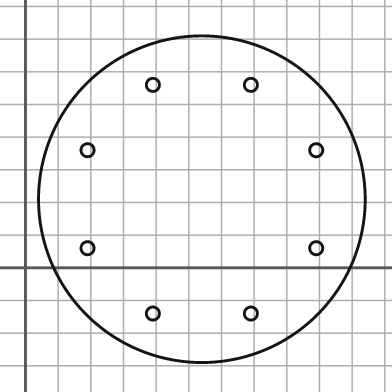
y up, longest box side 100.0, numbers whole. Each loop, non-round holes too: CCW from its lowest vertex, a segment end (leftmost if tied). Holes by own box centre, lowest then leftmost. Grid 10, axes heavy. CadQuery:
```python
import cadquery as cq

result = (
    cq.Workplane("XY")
    .moveTo(54.0, 21.0)
    .circle(50.0)
    .moveTo(39.0, -14.0)
    .circle(2.0)
    .moveTo(69.0, -14.0)
    .circle(2.0)
    .moveTo(19.0, 6.0)
    .circle(2.0)
    .moveTo(89.0, 6.0)
    .circle(2.0)
    .moveTo(19.0, 36.0)
    .circle(2.0)
    .moveTo(89.0, 36.0)
    .circle(2.0)
    .moveTo(39.0, 56.0)
    .circle(2.0)
    .moveTo(69.0, 56.0)
    .circle(2.0)
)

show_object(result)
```